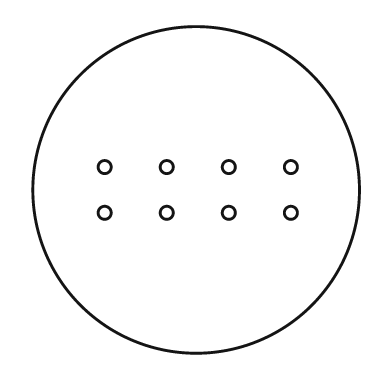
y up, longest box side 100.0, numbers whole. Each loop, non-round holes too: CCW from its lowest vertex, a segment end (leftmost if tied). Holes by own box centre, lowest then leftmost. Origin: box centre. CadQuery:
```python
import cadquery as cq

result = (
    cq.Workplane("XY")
    .moveTo(0.0, 0.0)
    .circle(50.0)
    .moveTo(-28.0, -7.0)
    .circle(2.0)
    .moveTo(-9.0, -7.0)
    .circle(2.0)
    .moveTo(10.0, -7.0)
    .circle(2.0)
    .moveTo(29.0, -7.0)
    .circle(2.0)
    .moveTo(-28.0, 7.0)
    .circle(2.0)
    .moveTo(-9.0, 7.0)
    .circle(2.0)
    .moveTo(10.0, 7.0)
    .circle(2.0)
    .moveTo(29.0, 7.0)
    .circle(2.0)
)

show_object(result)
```